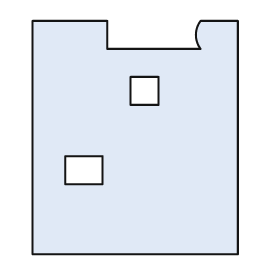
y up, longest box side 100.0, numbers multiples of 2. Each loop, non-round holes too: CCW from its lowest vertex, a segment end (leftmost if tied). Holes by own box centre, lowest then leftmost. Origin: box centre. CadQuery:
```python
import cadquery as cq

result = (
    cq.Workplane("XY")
    .moveTo(-44.0, -50.0)
    .lineTo(44.0, -50.0)
    .lineTo(44.0, 50.0)
    .lineTo(28.0, 50.0)
    .threePointArc((26.0, 44.0), (28.0, 38.0))
    .lineTo(-12.0, 38.0)
    .lineTo(-12.0, 50.0)
    .lineTo(-44.0, 50.0)
    .close()
    .moveTo(-30.0, -20.0)
    .lineTo(-14.0, -20.0)
    .lineTo(-14.0, -8.0)
    .lineTo(-30.0, -8.0)
    .close()
    .moveTo(-2.0, 14.0)
    .lineTo(10.0, 14.0)
    .lineTo(10.0, 26.0)
    .lineTo(-2.0, 26.0)
    .close()
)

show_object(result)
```